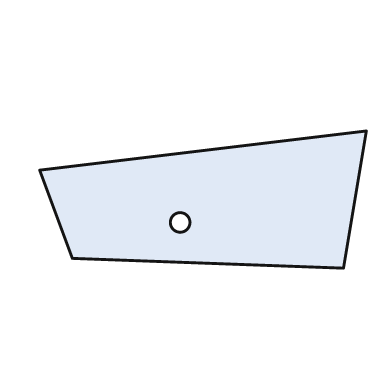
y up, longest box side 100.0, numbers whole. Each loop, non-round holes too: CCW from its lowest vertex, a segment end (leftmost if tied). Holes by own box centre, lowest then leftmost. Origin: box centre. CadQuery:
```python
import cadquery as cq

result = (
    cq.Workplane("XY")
    .moveTo(43.0, -21.0)
    .lineTo(50.0, 21.0)
    .lineTo(-50.0, 9.0)
    .lineTo(-40.0, -18.0)
    .close()
    .moveTo(-7.0, -7.0)
    .circle(3.0)
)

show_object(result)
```